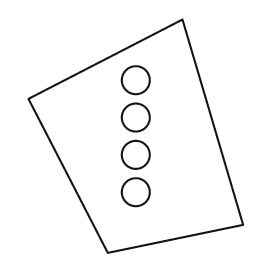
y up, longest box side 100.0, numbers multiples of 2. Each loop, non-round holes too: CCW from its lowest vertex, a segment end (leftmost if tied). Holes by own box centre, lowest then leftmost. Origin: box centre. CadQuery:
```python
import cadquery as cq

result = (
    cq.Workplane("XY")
    .moveTo(-12.0, -50.0)
    .lineTo(46.0, -38.0)
    .lineTo(20.0, 50.0)
    .lineTo(-46.0, 16.0)
    .close()
    .moveTo(0.0, -24.0)
    .circle(6.0)
    .moveTo(0.0, -8.0)
    .circle(6.0)
    .moveTo(0.0, 8.0)
    .circle(6.0)
    .moveTo(0.0, 24.0)
    .circle(6.0)
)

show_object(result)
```